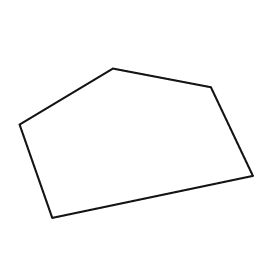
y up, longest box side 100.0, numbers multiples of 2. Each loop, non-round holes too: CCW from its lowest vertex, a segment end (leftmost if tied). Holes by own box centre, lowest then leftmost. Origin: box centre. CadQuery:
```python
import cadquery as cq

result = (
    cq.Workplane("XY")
    .moveTo(-36.0, -32.0)
    .lineTo(50.0, -14.0)
    .lineTo(32.0, 24.0)
    .lineTo(-10.0, 32.0)
    .lineTo(-50.0, 8.0)
    .close()
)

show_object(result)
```